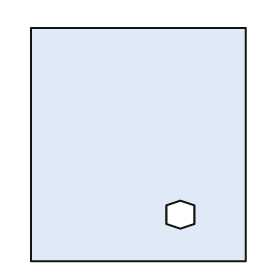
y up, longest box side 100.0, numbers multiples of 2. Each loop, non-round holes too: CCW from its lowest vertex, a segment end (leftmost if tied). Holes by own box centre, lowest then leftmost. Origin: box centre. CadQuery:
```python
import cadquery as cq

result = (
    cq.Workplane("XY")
    .moveTo(-46.0, -50.0)
    .lineTo(46.0, -50.0)
    .lineTo(46.0, 50.0)
    .lineTo(-46.0, 50.0)
    .close()
    .moveTo(18.0, -36.0)
    .lineTo(24.0, -34.0)
    .lineTo(24.0, -26.0)
    .lineTo(18.0, -24.0)
    .lineTo(12.0, -26.0)
    .lineTo(12.0, -34.0)
    .close()
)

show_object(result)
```